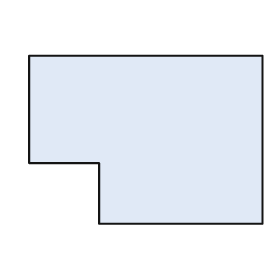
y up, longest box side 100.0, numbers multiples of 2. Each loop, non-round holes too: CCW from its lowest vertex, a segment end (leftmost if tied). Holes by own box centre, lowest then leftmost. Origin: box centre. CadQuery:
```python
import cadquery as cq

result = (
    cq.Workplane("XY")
    .moveTo(-20.0, -36.0)
    .lineTo(50.0, -36.0)
    .lineTo(50.0, 36.0)
    .lineTo(-50.0, 36.0)
    .lineTo(-50.0, -10.0)
    .lineTo(-20.0, -10.0)
    .close()
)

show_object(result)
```